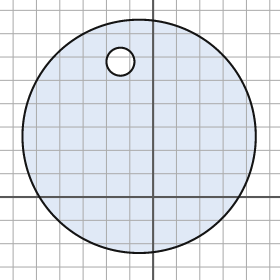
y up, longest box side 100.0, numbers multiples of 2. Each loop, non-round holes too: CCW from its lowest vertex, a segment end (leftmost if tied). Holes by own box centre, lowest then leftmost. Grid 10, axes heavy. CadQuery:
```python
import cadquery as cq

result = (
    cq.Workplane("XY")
    .moveTo(-6.0, 26.0)
    .circle(50.0)
    .moveTo(-14.0, 58.0)
    .circle(6.0)
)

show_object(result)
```